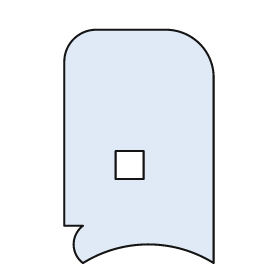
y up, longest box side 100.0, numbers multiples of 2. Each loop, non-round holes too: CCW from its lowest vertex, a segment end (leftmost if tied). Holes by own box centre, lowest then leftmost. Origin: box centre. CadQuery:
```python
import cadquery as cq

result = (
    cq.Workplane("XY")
    .moveTo(-24.0, -50.0)
    .threePointArc((4.0, -42.0), (32.0, -50.0))
    .lineTo(32.0, 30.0)
    .threePointArc((26.0, 44.0), (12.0, 50.0))
    .lineTo(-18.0, 50.0)
    .threePointArc((-28.0, 46.0), (-32.0, 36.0))
    .lineTo(-32.0, -34.0)
    .lineTo(-24.0, -34.0)
    .threePointArc((-28.0, -42.0), (-24.0, -50.0))
    .close()
    .moveTo(-10.0, -14.0)
    .lineTo(2.0, -14.0)
    .lineTo(2.0, -2.0)
    .lineTo(-10.0, -2.0)
    .close()
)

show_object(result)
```